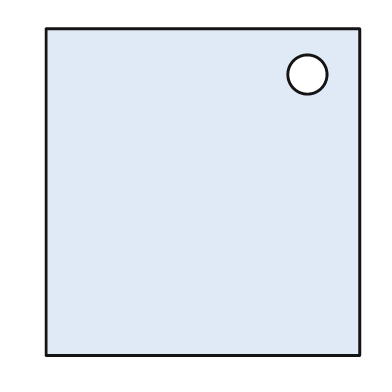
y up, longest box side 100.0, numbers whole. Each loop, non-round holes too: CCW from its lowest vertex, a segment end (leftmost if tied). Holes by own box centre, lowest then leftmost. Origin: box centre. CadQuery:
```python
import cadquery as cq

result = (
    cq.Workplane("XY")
    .moveTo(-48.0, -50.0)
    .lineTo(48.0, -50.0)
    .lineTo(48.0, 50.0)
    .lineTo(-48.0, 50.0)
    .close()
    .moveTo(32.0, 36.0)
    .circle(6.0)
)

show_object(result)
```